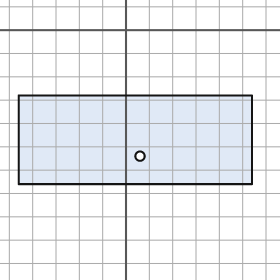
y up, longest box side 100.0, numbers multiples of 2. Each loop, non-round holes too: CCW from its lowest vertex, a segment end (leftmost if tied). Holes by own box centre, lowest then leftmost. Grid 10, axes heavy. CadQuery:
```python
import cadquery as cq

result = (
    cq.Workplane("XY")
    .moveTo(-46.0, -66.0)
    .lineTo(54.0, -66.0)
    .lineTo(54.0, -28.0)
    .lineTo(-46.0, -28.0)
    .close()
    .moveTo(6.0, -54.0)
    .circle(2.0)
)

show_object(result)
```